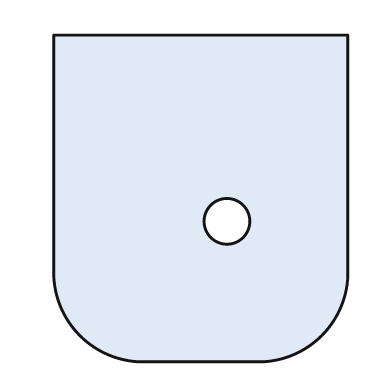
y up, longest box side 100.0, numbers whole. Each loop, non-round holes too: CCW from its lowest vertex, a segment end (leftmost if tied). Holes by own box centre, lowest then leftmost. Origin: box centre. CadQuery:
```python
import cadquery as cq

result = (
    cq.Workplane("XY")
    .moveTo(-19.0, -50.0)
    .lineTo(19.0, -50.0)
    .threePointArc((37.0, -42.0), (45.0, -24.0))
    .lineTo(45.0, 50.0)
    .lineTo(-45.0, 50.0)
    .lineTo(-45.0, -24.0)
    .threePointArc((-37.0, -42.0), (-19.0, -50.0))
    .close()
    .moveTo(8.0, -7.0)
    .circle(7.0)
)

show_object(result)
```